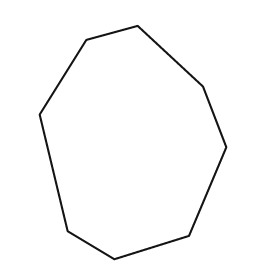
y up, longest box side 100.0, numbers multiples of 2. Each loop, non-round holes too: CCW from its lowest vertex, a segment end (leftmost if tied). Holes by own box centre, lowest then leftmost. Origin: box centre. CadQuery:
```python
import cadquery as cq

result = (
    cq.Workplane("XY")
    .moveTo(-8.0, -50.0)
    .lineTo(24.0, -40.0)
    .lineTo(40.0, -2.0)
    .lineTo(30.0, 24.0)
    .lineTo(2.0, 50.0)
    .lineTo(-20.0, 44.0)
    .lineTo(-40.0, 12.0)
    .lineTo(-28.0, -38.0)
    .close()
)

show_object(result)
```